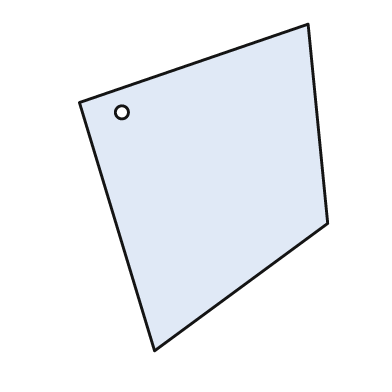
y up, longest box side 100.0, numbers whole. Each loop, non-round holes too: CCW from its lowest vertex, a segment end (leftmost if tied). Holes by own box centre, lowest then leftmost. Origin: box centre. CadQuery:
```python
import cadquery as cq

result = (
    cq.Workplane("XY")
    .moveTo(-15.0, -50.0)
    .lineTo(38.0, -11.0)
    .lineTo(32.0, 50.0)
    .lineTo(-38.0, 26.0)
    .close()
    .moveTo(-25.0, 23.0)
    .circle(2.0)
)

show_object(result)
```